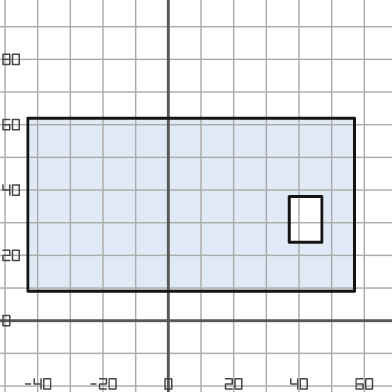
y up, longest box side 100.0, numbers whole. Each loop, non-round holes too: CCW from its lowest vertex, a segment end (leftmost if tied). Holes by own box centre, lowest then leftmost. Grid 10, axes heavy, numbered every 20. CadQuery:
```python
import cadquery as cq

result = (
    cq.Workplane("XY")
    .moveTo(-43.0, 9.0)
    .lineTo(57.0, 9.0)
    .lineTo(57.0, 62.0)
    .lineTo(-43.0, 62.0)
    .close()
    .moveTo(37.0, 24.0)
    .lineTo(47.0, 24.0)
    .lineTo(47.0, 38.0)
    .lineTo(37.0, 38.0)
    .close()
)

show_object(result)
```